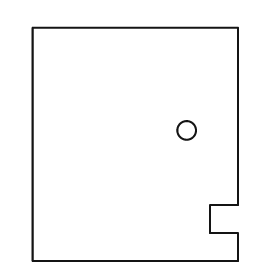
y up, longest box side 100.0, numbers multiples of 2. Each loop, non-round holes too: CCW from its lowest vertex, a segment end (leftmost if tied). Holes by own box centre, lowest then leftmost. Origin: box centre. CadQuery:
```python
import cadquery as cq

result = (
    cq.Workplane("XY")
    .moveTo(-44.0, -50.0)
    .lineTo(44.0, -50.0)
    .lineTo(44.0, -38.0)
    .lineTo(32.0, -38.0)
    .lineTo(32.0, -26.0)
    .lineTo(44.0, -26.0)
    .lineTo(44.0, 50.0)
    .lineTo(-44.0, 50.0)
    .close()
    .moveTo(22.0, 6.0)
    .circle(4.0)
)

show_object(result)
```